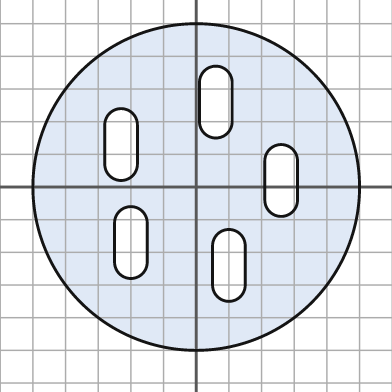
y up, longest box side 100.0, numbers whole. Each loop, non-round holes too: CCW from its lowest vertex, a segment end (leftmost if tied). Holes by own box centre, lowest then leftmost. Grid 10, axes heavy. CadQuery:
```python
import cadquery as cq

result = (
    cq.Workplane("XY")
    .moveTo(0.0, 0.0)
    .circle(50.0)
    .moveTo(5.0, -30.0)
    .threePointArc((10.0, -35.0), (15.0, -30.0))
    .lineTo(15.0, -18.0)
    .threePointArc((10.0, -13.0), (5.0, -18.0))
    .close()
    .moveTo(-25.0, -23.0)
    .threePointArc((-20.0, -28.0), (-15.0, -23.0))
    .lineTo(-15.0, -11.0)
    .threePointArc((-20.0, -6.0), (-25.0, -11.0))
    .close()
    .moveTo(21.0, -4.0)
    .threePointArc((26.0, -9.0), (31.0, -4.0))
    .lineTo(31.0, 8.0)
    .threePointArc((26.0, 13.0), (21.0, 8.0))
    .close()
    .moveTo(-28.0, 7.0)
    .threePointArc((-23.0, 2.0), (-18.0, 7.0))
    .lineTo(-18.0, 19.0)
    .threePointArc((-23.0, 24.0), (-28.0, 19.0))
    .close()
    .moveTo(1.0, 20.0)
    .threePointArc((6.0, 15.0), (11.0, 20.0))
    .lineTo(11.0, 32.0)
    .threePointArc((6.0, 37.0), (1.0, 32.0))
    .close()
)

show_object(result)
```